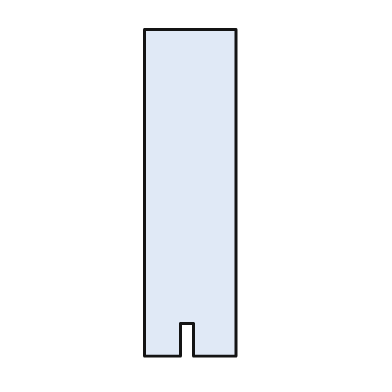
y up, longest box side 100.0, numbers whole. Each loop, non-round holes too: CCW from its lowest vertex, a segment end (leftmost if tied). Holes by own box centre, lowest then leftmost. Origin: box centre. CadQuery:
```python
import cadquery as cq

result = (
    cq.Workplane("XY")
    .moveTo(-14.0, -50.0)
    .lineTo(-3.0, -50.0)
    .lineTo(-3.0, -40.0)
    .lineTo(1.0, -40.0)
    .lineTo(1.0, -50.0)
    .lineTo(14.0, -50.0)
    .lineTo(14.0, 50.0)
    .lineTo(-14.0, 50.0)
    .close()
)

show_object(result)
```